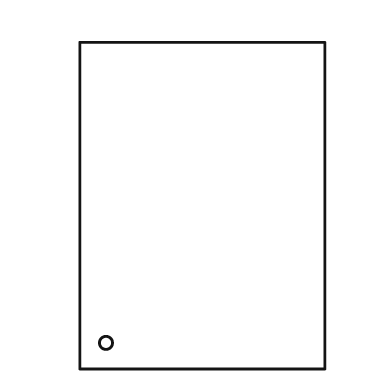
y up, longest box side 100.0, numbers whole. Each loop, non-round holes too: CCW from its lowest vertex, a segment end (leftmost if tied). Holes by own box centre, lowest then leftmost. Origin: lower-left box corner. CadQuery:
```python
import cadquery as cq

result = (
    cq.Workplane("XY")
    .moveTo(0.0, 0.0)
    .lineTo(75.0, 0.0)
    .lineTo(75.0, 100.0)
    .lineTo(0.0, 100.0)
    .close()
    .moveTo(8.0, 8.0)
    .circle(2.0)
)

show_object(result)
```